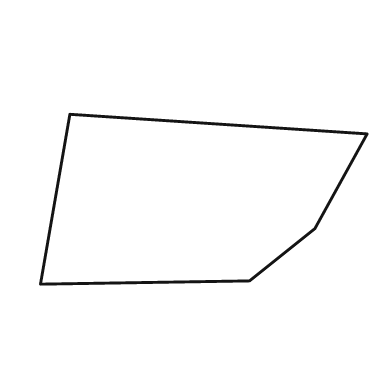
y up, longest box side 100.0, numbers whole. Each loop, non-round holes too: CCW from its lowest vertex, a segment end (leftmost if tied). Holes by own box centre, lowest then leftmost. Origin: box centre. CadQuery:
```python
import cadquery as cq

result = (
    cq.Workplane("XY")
    .moveTo(-50.0, -26.0)
    .lineTo(14.0, -25.0)
    .lineTo(34.0, -9.0)
    .lineTo(50.0, 20.0)
    .lineTo(-41.0, 26.0)
    .close()
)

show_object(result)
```